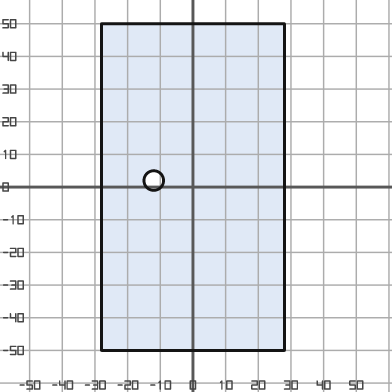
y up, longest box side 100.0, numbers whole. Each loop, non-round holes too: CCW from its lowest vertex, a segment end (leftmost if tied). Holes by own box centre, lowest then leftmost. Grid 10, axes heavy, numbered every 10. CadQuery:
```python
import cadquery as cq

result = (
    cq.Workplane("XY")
    .moveTo(-28.0, -50.0)
    .lineTo(28.0, -50.0)
    .lineTo(28.0, 50.0)
    .lineTo(-28.0, 50.0)
    .close()
    .moveTo(-12.0, 2.0)
    .circle(3.0)
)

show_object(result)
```